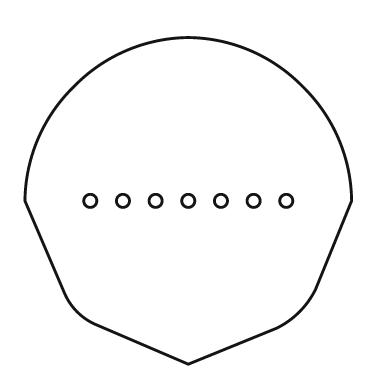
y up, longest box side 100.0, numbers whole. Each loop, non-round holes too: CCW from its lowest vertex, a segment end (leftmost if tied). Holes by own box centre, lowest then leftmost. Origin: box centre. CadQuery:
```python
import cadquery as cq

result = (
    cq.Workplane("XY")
    .moveTo(0.0, -50.0)
    .lineTo(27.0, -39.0)
    .threePointArc((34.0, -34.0), (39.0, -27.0))
    .lineTo(50.0, 0.0)
    .threePointArc((46.0, 19.0), (35.0, 35.0))
    .threePointArc((19.0, 46.0), (0.0, 50.0))
    .threePointArc((-19.0, 46.0), (-35.0, 35.0))
    .threePointArc((-46.0, 19.0), (-50.0, 0.0))
    .lineTo(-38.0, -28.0)
    .threePointArc((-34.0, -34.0), (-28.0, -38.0))
    .close()
    .moveTo(-30.0, 0.0)
    .circle(2.0)
    .moveTo(-20.0, 0.0)
    .circle(2.0)
    .moveTo(-10.0, 0.0)
    .circle(2.0)
    .moveTo(0.0, 0.0)
    .circle(2.0)
    .moveTo(10.0, 0.0)
    .circle(2.0)
    .moveTo(20.0, 0.0)
    .circle(2.0)
    .moveTo(30.0, 0.0)
    .circle(2.0)
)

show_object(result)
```